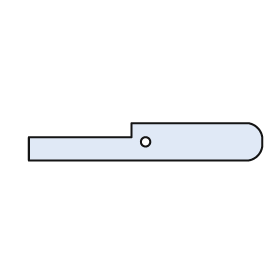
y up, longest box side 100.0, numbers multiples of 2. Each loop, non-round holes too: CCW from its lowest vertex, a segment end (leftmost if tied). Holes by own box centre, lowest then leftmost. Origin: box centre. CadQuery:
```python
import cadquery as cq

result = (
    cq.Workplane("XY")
    .moveTo(-50.0, -8.0)
    .lineTo(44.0, -8.0)
    .threePointArc((48.0, -6.0), (50.0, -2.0))
    .lineTo(50.0, 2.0)
    .threePointArc((48.0, 6.0), (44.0, 8.0))
    .lineTo(-6.0, 8.0)
    .lineTo(-6.0, 2.0)
    .lineTo(-50.0, 2.0)
    .close()
    .moveTo(0.0, 0.0)
    .circle(2.0)
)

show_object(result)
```